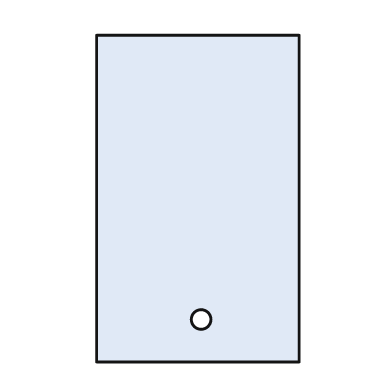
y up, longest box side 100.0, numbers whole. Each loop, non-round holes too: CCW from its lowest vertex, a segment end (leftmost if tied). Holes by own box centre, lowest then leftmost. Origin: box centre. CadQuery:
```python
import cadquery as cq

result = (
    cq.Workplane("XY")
    .moveTo(-31.0, -50.0)
    .lineTo(31.0, -50.0)
    .lineTo(31.0, 50.0)
    .lineTo(-31.0, 50.0)
    .close()
    .moveTo(1.0, -37.0)
    .circle(3.0)
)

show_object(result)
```